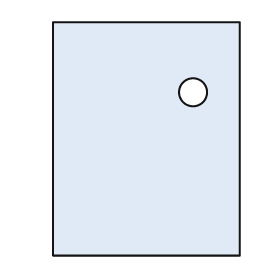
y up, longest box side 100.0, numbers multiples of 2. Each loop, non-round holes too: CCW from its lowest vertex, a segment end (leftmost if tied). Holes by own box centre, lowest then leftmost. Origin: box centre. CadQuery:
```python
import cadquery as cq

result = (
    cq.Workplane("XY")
    .moveTo(-40.0, -50.0)
    .lineTo(40.0, -50.0)
    .lineTo(40.0, 50.0)
    .lineTo(-40.0, 50.0)
    .close()
    .moveTo(20.0, 20.0)
    .circle(6.0)
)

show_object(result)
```